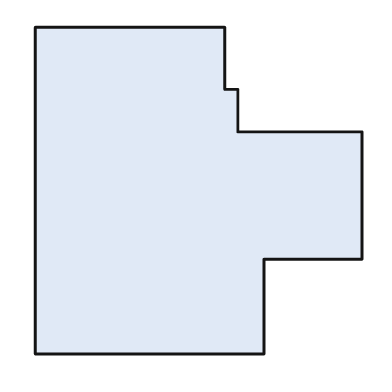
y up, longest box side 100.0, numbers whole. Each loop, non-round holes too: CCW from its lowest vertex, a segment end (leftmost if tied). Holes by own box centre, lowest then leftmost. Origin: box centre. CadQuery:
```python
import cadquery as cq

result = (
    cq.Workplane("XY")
    .moveTo(-50.0, -50.0)
    .lineTo(20.0, -50.0)
    .lineTo(20.0, -21.0)
    .lineTo(50.0, -21.0)
    .lineTo(50.0, 18.0)
    .lineTo(12.0, 18.0)
    .lineTo(12.0, 31.0)
    .lineTo(8.0, 31.0)
    .lineTo(8.0, 50.0)
    .lineTo(-50.0, 50.0)
    .close()
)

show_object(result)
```